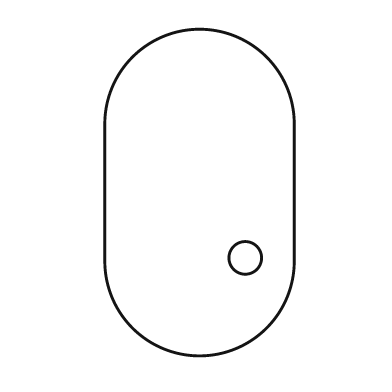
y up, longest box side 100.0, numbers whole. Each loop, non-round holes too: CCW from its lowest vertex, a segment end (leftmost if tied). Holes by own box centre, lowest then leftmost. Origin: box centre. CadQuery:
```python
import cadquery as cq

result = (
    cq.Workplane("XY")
    .moveTo(-29.0, -21.0)
    .threePointArc((0.0, -50.0), (29.0, -21.0))
    .lineTo(29.0, 21.0)
    .threePointArc((0.0, 50.0), (-29.0, 21.0))
    .close()
    .moveTo(14.0, -20.0)
    .circle(5.0)
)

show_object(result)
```